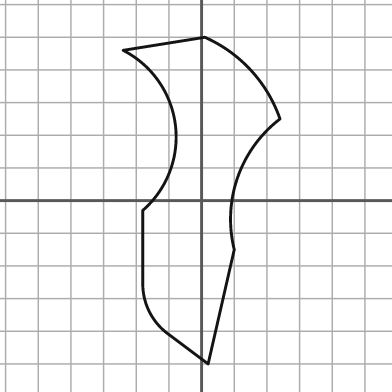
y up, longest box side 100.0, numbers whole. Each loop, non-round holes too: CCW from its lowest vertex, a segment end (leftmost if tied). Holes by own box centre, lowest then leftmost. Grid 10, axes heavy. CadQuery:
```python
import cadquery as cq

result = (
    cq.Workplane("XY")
    .moveTo(2.0, -50.0)
    .lineTo(10.0, -15.0)
    .threePointArc((11.0, 7.0), (24.0, 25.0))
    .threePointArc((15.0, 40.0), (1.0, 50.0))
    .lineTo(-24.0, 46.0)
    .threePointArc((-8.0, 23.0), (-18.0, -3.0))
    .lineTo(-18.0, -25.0)
    .threePointArc((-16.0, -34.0), (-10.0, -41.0))
    .close()
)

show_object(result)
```